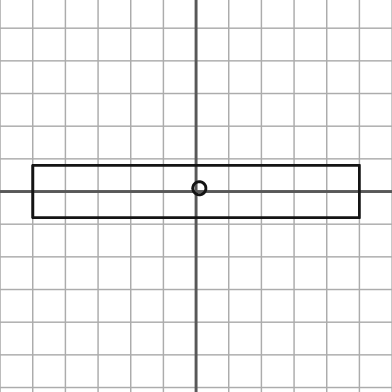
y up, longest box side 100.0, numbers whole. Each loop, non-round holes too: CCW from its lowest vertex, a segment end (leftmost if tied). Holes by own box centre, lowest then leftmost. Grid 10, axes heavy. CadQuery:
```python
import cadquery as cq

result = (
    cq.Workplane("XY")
    .moveTo(-50.0, -8.0)
    .lineTo(50.0, -8.0)
    .lineTo(50.0, 8.0)
    .lineTo(-50.0, 8.0)
    .close()
    .moveTo(1.0, 1.0)
    .circle(2.0)
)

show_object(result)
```